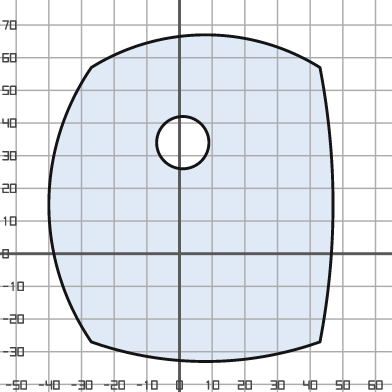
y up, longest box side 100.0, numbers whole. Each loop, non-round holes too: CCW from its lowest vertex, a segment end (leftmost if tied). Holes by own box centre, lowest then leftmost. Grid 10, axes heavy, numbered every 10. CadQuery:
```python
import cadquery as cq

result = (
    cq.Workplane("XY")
    .moveTo(-27.0, -27.0)
    .threePointArc((8.0, -33.0), (43.0, -27.0))
    .threePointArc((47.0, 15.0), (43.0, 57.0))
    .threePointArc((8.0, 67.0), (-27.0, 57.0))
    .threePointArc((-40.0, 15.0), (-27.0, -27.0))
    .close()
    .moveTo(1.0, 34.0)
    .circle(8.0)
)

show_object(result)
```